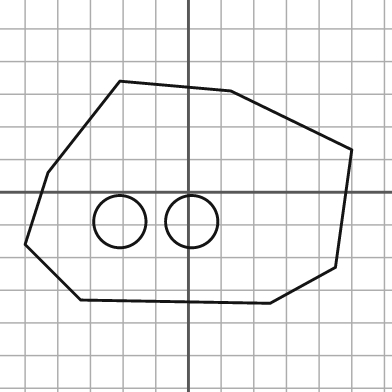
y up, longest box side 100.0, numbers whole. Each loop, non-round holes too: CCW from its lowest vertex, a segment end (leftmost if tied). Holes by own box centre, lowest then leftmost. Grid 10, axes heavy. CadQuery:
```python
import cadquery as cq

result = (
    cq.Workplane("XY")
    .moveTo(25.0, -34.0)
    .lineTo(45.0, -23.0)
    .lineTo(50.0, 13.0)
    .lineTo(13.0, 31.0)
    .lineTo(-21.0, 34.0)
    .lineTo(-43.0, 6.0)
    .lineTo(-50.0, -16.0)
    .lineTo(-33.0, -33.0)
    .close()
    .moveTo(-21.0, -9.0)
    .circle(8.0)
    .moveTo(1.0, -9.0)
    .circle(8.0)
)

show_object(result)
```